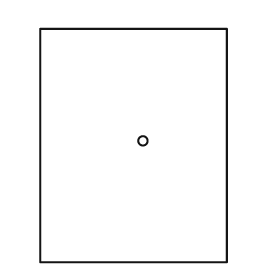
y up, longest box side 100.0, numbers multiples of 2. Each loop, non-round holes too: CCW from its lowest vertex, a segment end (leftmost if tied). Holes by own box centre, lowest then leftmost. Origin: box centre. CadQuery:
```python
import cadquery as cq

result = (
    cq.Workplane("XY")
    .moveTo(-40.0, -50.0)
    .lineTo(40.0, -50.0)
    .lineTo(40.0, 50.0)
    .lineTo(-40.0, 50.0)
    .close()
    .moveTo(4.0, 2.0)
    .circle(2.0)
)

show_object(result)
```